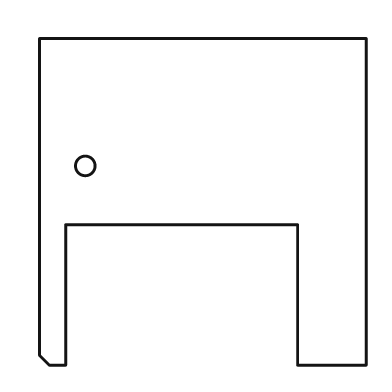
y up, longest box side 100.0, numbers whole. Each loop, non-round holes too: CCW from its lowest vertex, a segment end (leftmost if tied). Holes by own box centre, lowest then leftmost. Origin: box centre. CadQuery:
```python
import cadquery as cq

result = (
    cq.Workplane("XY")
    .moveTo(-47.0, -50.0)
    .lineTo(-42.0, -50.0)
    .lineTo(-42.0, -7.0)
    .lineTo(29.0, -7.0)
    .lineTo(29.0, -50.0)
    .lineTo(50.0, -50.0)
    .lineTo(50.0, 50.0)
    .lineTo(-50.0, 50.0)
    .lineTo(-50.0, -47.0)
    .close()
    .moveTo(-36.0, 11.0)
    .circle(3.0)
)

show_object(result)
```